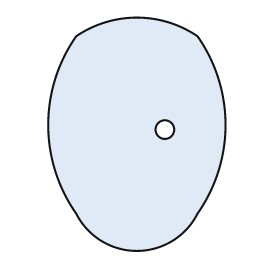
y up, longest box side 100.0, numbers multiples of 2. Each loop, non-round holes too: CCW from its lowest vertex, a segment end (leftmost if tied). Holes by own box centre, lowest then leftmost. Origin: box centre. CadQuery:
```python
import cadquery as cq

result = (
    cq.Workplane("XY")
    .moveTo(-26.0, -34.0)
    .threePointArc((0.0, -50.0), (26.0, -34.0))
    .threePointArc((38.0, 4.0), (26.0, 42.0))
    .threePointArc((0.0, 50.0), (-26.0, 42.0))
    .threePointArc((-38.0, 4.0), (-26.0, -34.0))
    .close()
    .moveTo(12.0, 2.0)
    .circle(4.0)
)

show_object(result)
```